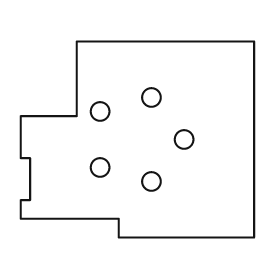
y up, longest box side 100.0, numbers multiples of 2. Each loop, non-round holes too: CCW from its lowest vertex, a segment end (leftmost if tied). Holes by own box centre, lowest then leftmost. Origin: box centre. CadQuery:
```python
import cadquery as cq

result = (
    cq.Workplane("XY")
    .moveTo(-8.0, -42.0)
    .lineTo(50.0, -42.0)
    .lineTo(50.0, 42.0)
    .lineTo(-26.0, 42.0)
    .lineTo(-26.0, 10.0)
    .lineTo(-50.0, 10.0)
    .lineTo(-50.0, -8.0)
    .lineTo(-46.0, -8.0)
    .lineTo(-46.0, -26.0)
    .lineTo(-50.0, -26.0)
    .lineTo(-50.0, -34.0)
    .lineTo(-8.0, -34.0)
    .close()
    .moveTo(6.0, -18.0)
    .circle(4.0)
    .moveTo(-16.0, -12.0)
    .circle(4.0)
    .moveTo(20.0, 0.0)
    .circle(4.0)
    .moveTo(-16.0, 12.0)
    .circle(4.0)
    .moveTo(6.0, 18.0)
    .circle(4.0)
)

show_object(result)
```